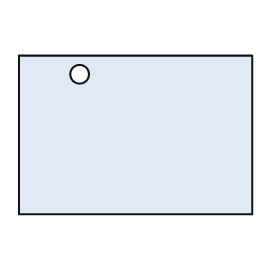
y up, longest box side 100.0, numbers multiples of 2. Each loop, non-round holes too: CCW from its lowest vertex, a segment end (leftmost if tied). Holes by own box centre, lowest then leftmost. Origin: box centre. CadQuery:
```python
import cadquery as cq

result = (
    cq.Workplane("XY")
    .moveTo(-50.0, -34.0)
    .lineTo(50.0, -34.0)
    .lineTo(50.0, 34.0)
    .lineTo(-50.0, 34.0)
    .close()
    .moveTo(-24.0, 26.0)
    .circle(4.0)
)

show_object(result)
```